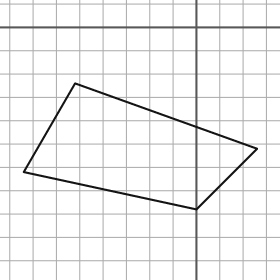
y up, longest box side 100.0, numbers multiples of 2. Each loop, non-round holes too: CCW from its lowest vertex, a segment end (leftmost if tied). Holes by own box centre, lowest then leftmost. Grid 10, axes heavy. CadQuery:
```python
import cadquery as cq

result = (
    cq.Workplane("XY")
    .moveTo(0.0, -78.0)
    .lineTo(26.0, -52.0)
    .lineTo(-52.0, -24.0)
    .lineTo(-74.0, -62.0)
    .close()
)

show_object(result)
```